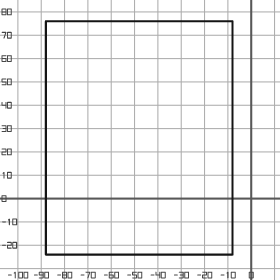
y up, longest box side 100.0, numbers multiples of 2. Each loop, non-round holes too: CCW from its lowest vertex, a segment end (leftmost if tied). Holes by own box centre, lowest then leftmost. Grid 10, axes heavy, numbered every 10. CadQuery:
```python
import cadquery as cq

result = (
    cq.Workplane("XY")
    .moveTo(-88.0, -24.0)
    .lineTo(-8.0, -24.0)
    .lineTo(-8.0, 76.0)
    .lineTo(-88.0, 76.0)
    .close()
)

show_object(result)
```